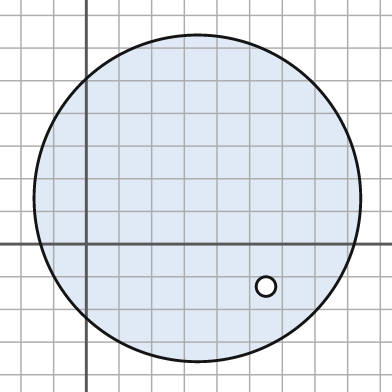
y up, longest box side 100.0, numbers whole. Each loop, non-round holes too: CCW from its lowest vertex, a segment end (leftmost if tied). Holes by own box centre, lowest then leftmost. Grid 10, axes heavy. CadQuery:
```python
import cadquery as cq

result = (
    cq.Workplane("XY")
    .moveTo(34.0, 14.0)
    .circle(50.0)
    .moveTo(55.0, -13.0)
    .circle(3.0)
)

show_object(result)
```